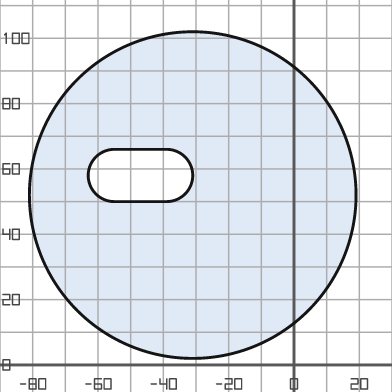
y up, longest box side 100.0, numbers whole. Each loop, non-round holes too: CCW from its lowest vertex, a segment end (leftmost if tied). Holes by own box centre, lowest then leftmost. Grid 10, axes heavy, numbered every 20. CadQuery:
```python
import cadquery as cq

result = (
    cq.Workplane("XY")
    .moveTo(-31.0, 52.0)
    .circle(50.0)
    .moveTo(-55.0, 50.0)
    .lineTo(-39.0, 50.0)
    .threePointArc((-31.0, 58.0), (-39.0, 66.0))
    .lineTo(-55.0, 66.0)
    .threePointArc((-63.0, 58.0), (-55.0, 50.0))
    .close()
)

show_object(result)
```